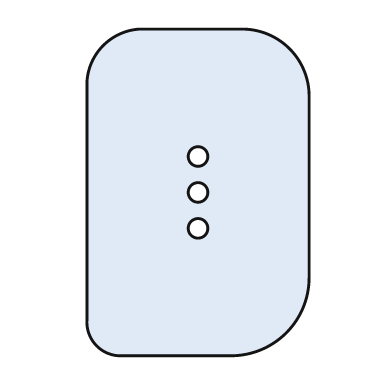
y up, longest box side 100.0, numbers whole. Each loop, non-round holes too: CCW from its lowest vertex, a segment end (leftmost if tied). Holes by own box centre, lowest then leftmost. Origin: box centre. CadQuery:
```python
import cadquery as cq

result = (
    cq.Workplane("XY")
    .moveTo(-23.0, -50.0)
    .lineTo(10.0, -50.0)
    .threePointArc((27.0, -43.0), (34.0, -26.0))
    .lineTo(34.0, 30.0)
    .threePointArc((28.0, 44.0), (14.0, 50.0))
    .lineTo(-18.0, 50.0)
    .threePointArc((-29.0, 45.0), (-34.0, 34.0))
    .lineTo(-34.0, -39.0)
    .threePointArc((-31.0, -47.0), (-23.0, -50.0))
    .close()
    .moveTo(0.0, -11.0)
    .circle(3.0)
    .moveTo(0.0, 0.0)
    .circle(3.0)
    .moveTo(0.0, 11.0)
    .circle(3.0)
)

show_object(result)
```